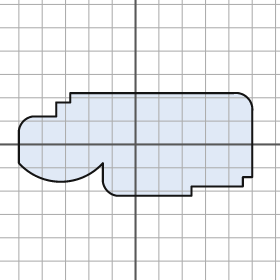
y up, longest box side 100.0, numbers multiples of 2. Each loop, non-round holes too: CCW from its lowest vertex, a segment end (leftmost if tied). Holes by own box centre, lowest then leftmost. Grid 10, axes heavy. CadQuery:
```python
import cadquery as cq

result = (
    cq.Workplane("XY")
    .moveTo(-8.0, -22.0)
    .lineTo(24.0, -22.0)
    .lineTo(24.0, -18.0)
    .lineTo(46.0, -18.0)
    .lineTo(46.0, -14.0)
    .lineTo(50.0, -14.0)
    .lineTo(50.0, 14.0)
    .threePointArc((48.0, 20.0), (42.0, 22.0))
    .lineTo(-28.0, 22.0)
    .lineTo(-28.0, 18.0)
    .lineTo(-34.0, 18.0)
    .lineTo(-34.0, 12.0)
    .lineTo(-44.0, 12.0)
    .threePointArc((-48.0, 10.0), (-50.0, 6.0))
    .lineTo(-50.0, -8.0)
    .threePointArc((-32.0, -16.0), (-14.0, -8.0))
    .lineTo(-14.0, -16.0)
    .threePointArc((-12.0, -20.0), (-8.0, -22.0))
    .close()
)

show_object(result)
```